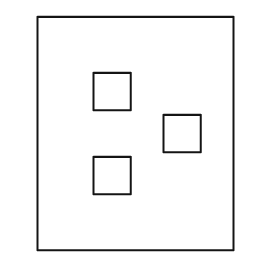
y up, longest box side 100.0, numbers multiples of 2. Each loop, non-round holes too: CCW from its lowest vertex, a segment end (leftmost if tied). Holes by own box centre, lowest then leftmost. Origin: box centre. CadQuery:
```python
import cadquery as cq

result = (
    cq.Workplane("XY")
    .moveTo(-42.0, -50.0)
    .lineTo(42.0, -50.0)
    .lineTo(42.0, 50.0)
    .lineTo(-42.0, 50.0)
    .close()
    .moveTo(-18.0, -26.0)
    .lineTo(-2.0, -26.0)
    .lineTo(-2.0, -10.0)
    .lineTo(-18.0, -10.0)
    .close()
    .moveTo(12.0, -8.0)
    .lineTo(28.0, -8.0)
    .lineTo(28.0, 8.0)
    .lineTo(12.0, 8.0)
    .close()
    .moveTo(-18.0, 10.0)
    .lineTo(-2.0, 10.0)
    .lineTo(-2.0, 26.0)
    .lineTo(-18.0, 26.0)
    .close()
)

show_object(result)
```